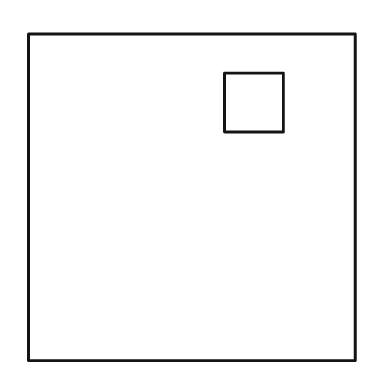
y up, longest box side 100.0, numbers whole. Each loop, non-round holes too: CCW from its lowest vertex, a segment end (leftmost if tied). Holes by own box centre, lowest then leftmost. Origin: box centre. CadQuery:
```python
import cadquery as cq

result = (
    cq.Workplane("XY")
    .moveTo(-50.0, -50.0)
    .lineTo(50.0, -50.0)
    .lineTo(50.0, 50.0)
    .lineTo(-50.0, 50.0)
    .close()
    .moveTo(10.0, 20.0)
    .lineTo(28.0, 20.0)
    .lineTo(28.0, 38.0)
    .lineTo(10.0, 38.0)
    .close()
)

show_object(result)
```